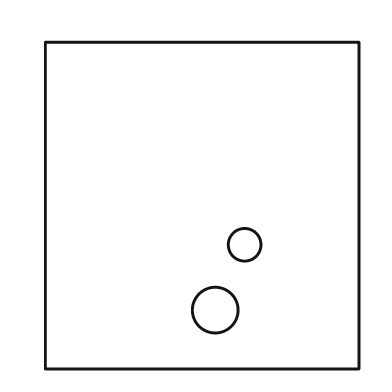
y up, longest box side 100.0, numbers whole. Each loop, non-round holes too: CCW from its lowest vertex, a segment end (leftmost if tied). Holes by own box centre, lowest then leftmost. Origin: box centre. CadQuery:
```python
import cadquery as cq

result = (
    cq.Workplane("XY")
    .moveTo(-48.0, -50.0)
    .lineTo(48.0, -50.0)
    .lineTo(48.0, 50.0)
    .lineTo(-48.0, 50.0)
    .close()
    .moveTo(4.0, -32.0)
    .circle(7.0)
    .moveTo(13.0, -12.0)
    .circle(5.0)
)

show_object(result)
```